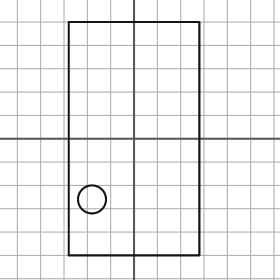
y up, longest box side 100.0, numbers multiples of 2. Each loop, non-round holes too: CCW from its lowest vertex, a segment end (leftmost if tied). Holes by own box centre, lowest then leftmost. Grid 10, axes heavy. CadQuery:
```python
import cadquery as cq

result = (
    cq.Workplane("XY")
    .moveTo(-28.0, -50.0)
    .lineTo(28.0, -50.0)
    .lineTo(28.0, 50.0)
    .lineTo(-28.0, 50.0)
    .close()
    .moveTo(-18.0, -26.0)
    .circle(6.0)
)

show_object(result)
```